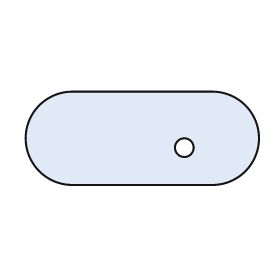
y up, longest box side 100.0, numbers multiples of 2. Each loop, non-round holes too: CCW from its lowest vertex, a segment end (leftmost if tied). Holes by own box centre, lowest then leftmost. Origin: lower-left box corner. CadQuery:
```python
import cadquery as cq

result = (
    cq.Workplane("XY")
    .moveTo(20.0, 0.0)
    .lineTo(80.0, 0.0)
    .threePointArc((100.0, 20.0), (80.0, 40.0))
    .lineTo(20.0, 40.0)
    .threePointArc((0.0, 20.0), (20.0, 0.0))
    .close()
    .moveTo(68.0, 16.0)
    .circle(4.0)
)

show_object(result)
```